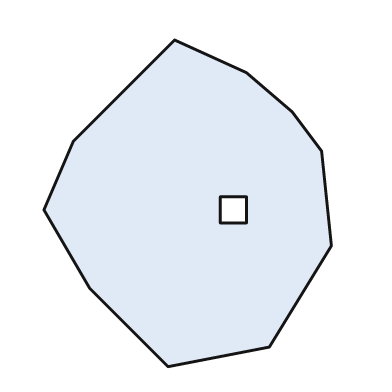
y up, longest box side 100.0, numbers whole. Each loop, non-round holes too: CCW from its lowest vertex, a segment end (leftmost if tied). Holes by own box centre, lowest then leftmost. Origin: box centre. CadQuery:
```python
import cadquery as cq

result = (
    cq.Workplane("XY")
    .moveTo(-6.0, -50.0)
    .lineTo(25.0, -44.0)
    .lineTo(44.0, -13.0)
    .lineTo(41.0, 16.0)
    .lineTo(32.0, 28.0)
    .lineTo(18.0, 40.0)
    .lineTo(-4.0, 50.0)
    .lineTo(-35.0, 19.0)
    .lineTo(-44.0, -2.0)
    .lineTo(-30.0, -26.0)
    .close()
    .moveTo(10.0, -6.0)
    .lineTo(18.0, -6.0)
    .lineTo(18.0, 2.0)
    .lineTo(10.0, 2.0)
    .close()
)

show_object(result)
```